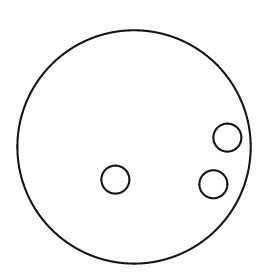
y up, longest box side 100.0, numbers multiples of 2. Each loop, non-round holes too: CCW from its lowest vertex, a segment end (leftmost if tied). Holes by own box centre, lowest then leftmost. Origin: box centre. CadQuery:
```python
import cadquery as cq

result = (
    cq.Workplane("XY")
    .moveTo(0.0, 0.0)
    .circle(50.0)
    .moveTo(34.0, -16.0)
    .circle(6.0)
    .moveTo(-8.0, -14.0)
    .circle(6.0)
    .moveTo(40.0, 4.0)
    .circle(6.0)
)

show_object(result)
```